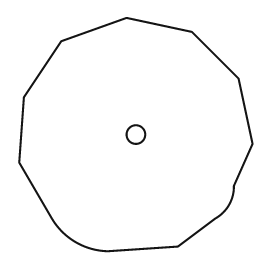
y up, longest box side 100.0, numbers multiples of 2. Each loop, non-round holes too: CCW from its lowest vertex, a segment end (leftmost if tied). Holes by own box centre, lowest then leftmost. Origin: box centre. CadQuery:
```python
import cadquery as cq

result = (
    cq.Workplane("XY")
    .moveTo(-12.0, -50.0)
    .lineTo(18.0, -48.0)
    .lineTo(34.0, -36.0)
    .threePointArc((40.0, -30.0), (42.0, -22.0))
    .lineTo(50.0, -4.0)
    .lineTo(44.0, 24.0)
    .lineTo(24.0, 44.0)
    .lineTo(-4.0, 50.0)
    .lineTo(-32.0, 40.0)
    .lineTo(-48.0, 16.0)
    .lineTo(-50.0, -12.0)
    .lineTo(-36.0, -36.0)
    .threePointArc((-26.0, -46.0), (-12.0, -50.0))
    .close()
    .moveTo(0.0, 0.0)
    .circle(4.0)
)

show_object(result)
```